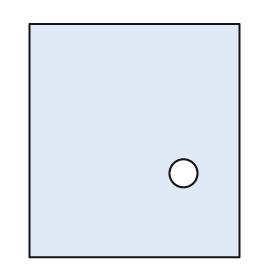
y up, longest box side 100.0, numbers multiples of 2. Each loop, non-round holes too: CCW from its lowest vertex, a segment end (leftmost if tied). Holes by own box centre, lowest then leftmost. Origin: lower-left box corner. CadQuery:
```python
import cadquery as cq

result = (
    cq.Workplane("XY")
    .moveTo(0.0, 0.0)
    .lineTo(90.0, 0.0)
    .lineTo(90.0, 100.0)
    .lineTo(0.0, 100.0)
    .close()
    .moveTo(66.0, 36.0)
    .circle(6.0)
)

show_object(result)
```